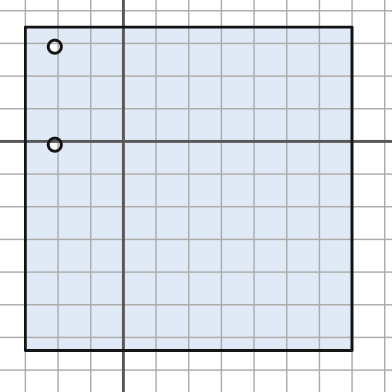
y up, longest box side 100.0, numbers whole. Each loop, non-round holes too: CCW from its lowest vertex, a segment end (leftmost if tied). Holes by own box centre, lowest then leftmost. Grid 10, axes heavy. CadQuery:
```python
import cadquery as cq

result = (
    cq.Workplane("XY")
    .moveTo(-30.0, -64.0)
    .lineTo(70.0, -64.0)
    .lineTo(70.0, 35.0)
    .lineTo(-30.0, 35.0)
    .close()
    .moveTo(-21.0, -1.0)
    .circle(2.0)
    .moveTo(-21.0, 29.0)
    .circle(2.0)
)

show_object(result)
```